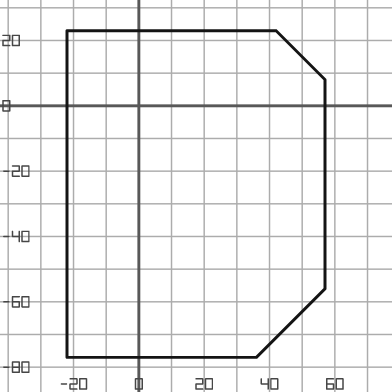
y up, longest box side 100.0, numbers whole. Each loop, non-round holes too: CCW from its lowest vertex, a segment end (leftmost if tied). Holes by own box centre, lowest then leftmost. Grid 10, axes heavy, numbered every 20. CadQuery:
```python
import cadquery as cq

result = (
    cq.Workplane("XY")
    .moveTo(-22.0, -77.0)
    .lineTo(36.0, -77.0)
    .lineTo(57.0, -56.0)
    .lineTo(57.0, 8.0)
    .lineTo(42.0, 23.0)
    .lineTo(-22.0, 23.0)
    .close()
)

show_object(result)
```